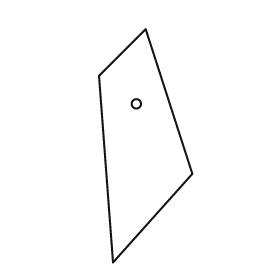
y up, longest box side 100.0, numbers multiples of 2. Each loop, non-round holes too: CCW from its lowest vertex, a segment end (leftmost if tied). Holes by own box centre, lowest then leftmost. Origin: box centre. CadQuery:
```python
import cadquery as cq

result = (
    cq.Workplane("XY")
    .moveTo(-14.0, -50.0)
    .lineTo(20.0, -12.0)
    .lineTo(0.0, 50.0)
    .lineTo(-20.0, 30.0)
    .close()
    .moveTo(-4.0, 18.0)
    .circle(2.0)
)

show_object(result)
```